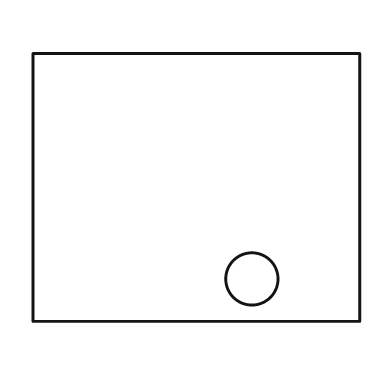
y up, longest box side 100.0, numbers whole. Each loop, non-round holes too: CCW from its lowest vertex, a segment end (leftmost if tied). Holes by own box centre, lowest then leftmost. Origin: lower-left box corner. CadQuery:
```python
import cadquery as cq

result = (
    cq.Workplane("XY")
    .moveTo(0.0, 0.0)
    .lineTo(100.0, 0.0)
    .lineTo(100.0, 82.0)
    .lineTo(0.0, 82.0)
    .close()
    .moveTo(67.0, 13.0)
    .circle(8.0)
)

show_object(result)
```